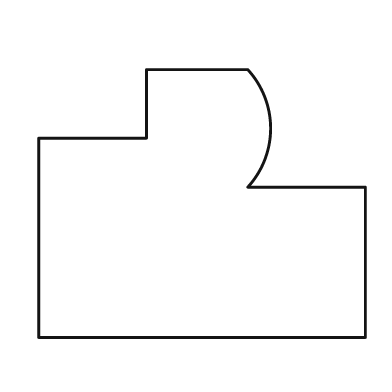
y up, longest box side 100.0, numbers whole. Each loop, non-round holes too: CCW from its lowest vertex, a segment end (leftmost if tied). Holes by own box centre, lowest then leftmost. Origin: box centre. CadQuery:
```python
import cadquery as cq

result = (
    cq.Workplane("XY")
    .moveTo(-50.0, -41.0)
    .lineTo(50.0, -41.0)
    .lineTo(50.0, 5.0)
    .lineTo(14.0, 5.0)
    .threePointArc((21.0, 23.0), (14.0, 41.0))
    .lineTo(-17.0, 41.0)
    .lineTo(-17.0, 20.0)
    .lineTo(-50.0, 20.0)
    .close()
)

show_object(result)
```